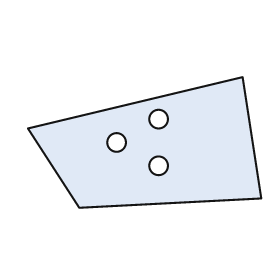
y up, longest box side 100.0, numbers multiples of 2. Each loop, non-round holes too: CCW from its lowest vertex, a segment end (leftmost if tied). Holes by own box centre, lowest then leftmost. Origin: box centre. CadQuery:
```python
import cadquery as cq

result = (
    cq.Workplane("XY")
    .moveTo(-28.0, -28.0)
    .lineTo(50.0, -24.0)
    .lineTo(42.0, 28.0)
    .lineTo(-50.0, 6.0)
    .close()
    .moveTo(6.0, -10.0)
    .circle(4.0)
    .moveTo(-12.0, 0.0)
    .circle(4.0)
    .moveTo(6.0, 10.0)
    .circle(4.0)
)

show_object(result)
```